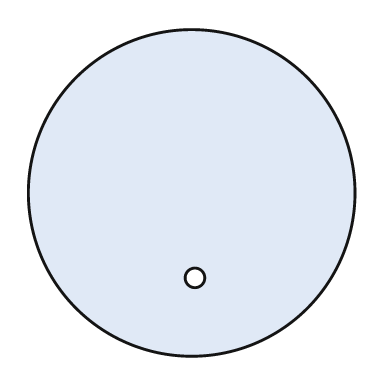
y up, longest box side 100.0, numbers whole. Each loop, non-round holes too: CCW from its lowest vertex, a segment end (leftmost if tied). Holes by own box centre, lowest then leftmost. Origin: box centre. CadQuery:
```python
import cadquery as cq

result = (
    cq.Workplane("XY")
    .moveTo(0.0, 0.0)
    .circle(50.0)
    .moveTo(1.0, -26.0)
    .circle(3.0)
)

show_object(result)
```